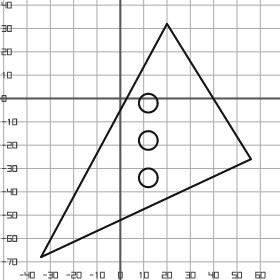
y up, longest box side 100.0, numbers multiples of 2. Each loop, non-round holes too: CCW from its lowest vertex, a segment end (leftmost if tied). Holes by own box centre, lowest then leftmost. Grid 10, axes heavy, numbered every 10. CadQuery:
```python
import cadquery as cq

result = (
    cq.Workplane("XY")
    .moveTo(-34.0, -68.0)
    .lineTo(56.0, -26.0)
    .lineTo(20.0, 32.0)
    .close()
    .moveTo(12.0, -34.0)
    .circle(4.0)
    .moveTo(12.0, -18.0)
    .circle(4.0)
    .moveTo(12.0, -2.0)
    .circle(4.0)
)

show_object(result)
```